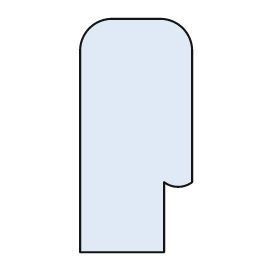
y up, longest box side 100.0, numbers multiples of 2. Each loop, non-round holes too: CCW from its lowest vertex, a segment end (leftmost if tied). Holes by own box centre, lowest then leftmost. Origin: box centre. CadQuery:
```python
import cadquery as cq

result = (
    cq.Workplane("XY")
    .moveTo(-24.0, -50.0)
    .lineTo(12.0, -50.0)
    .lineTo(12.0, -20.0)
    .threePointArc((18.0, -22.0), (24.0, -20.0))
    .lineTo(24.0, 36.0)
    .threePointArc((20.0, 46.0), (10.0, 50.0))
    .lineTo(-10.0, 50.0)
    .threePointArc((-20.0, 46.0), (-24.0, 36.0))
    .close()
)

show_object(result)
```